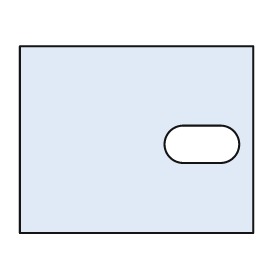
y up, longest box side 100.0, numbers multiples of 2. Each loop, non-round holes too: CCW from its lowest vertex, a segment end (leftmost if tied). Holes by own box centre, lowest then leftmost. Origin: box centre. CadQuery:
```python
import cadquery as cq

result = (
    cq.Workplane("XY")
    .moveTo(-50.0, -40.0)
    .lineTo(50.0, -40.0)
    .lineTo(50.0, 40.0)
    .lineTo(-50.0, 40.0)
    .close()
    .moveTo(20.0, -10.0)
    .lineTo(36.0, -10.0)
    .threePointArc((44.0, -2.0), (36.0, 6.0))
    .lineTo(20.0, 6.0)
    .threePointArc((12.0, -2.0), (20.0, -10.0))
    .close()
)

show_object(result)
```